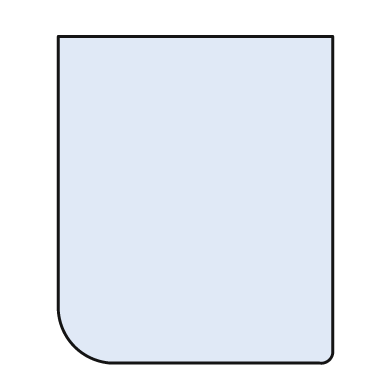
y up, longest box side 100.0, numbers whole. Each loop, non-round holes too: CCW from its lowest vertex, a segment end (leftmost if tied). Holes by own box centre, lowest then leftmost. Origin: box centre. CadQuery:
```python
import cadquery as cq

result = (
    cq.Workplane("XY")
    .moveTo(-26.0, -50.0)
    .lineTo(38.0, -50.0)
    .threePointArc((41.0, -49.0), (42.0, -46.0))
    .lineTo(42.0, 50.0)
    .lineTo(-42.0, 50.0)
    .lineTo(-42.0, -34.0)
    .threePointArc((-37.0, -45.0), (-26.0, -50.0))
    .close()
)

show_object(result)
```